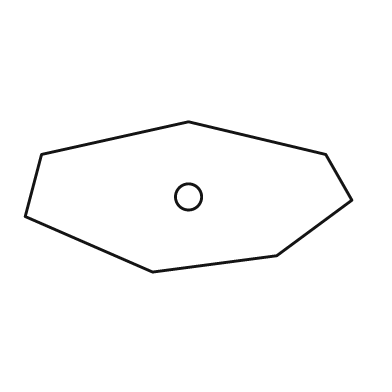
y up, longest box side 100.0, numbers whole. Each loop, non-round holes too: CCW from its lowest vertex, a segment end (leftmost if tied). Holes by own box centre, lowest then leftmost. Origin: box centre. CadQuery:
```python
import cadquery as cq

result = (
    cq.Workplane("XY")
    .moveTo(-11.0, -23.0)
    .lineTo(27.0, -18.0)
    .lineTo(50.0, -1.0)
    .lineTo(42.0, 13.0)
    .lineTo(0.0, 23.0)
    .lineTo(-45.0, 13.0)
    .lineTo(-50.0, -6.0)
    .close()
    .moveTo(0.0, 0.0)
    .circle(4.0)
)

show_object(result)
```